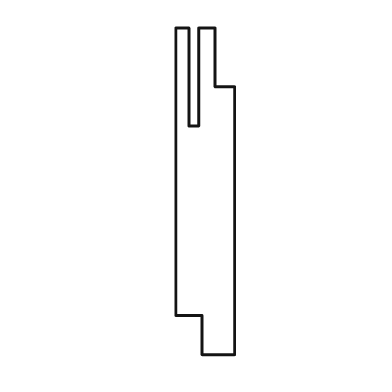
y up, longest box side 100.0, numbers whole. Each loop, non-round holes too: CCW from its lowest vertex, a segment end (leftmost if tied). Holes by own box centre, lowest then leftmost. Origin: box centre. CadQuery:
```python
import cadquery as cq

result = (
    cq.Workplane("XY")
    .moveTo(-1.0, -50.0)
    .lineTo(9.0, -50.0)
    .lineTo(9.0, 32.0)
    .lineTo(3.0, 32.0)
    .lineTo(3.0, 50.0)
    .lineTo(-2.0, 50.0)
    .lineTo(-2.0, 20.0)
    .lineTo(-5.0, 20.0)
    .lineTo(-5.0, 50.0)
    .lineTo(-9.0, 50.0)
    .lineTo(-9.0, -38.0)
    .lineTo(-1.0, -38.0)
    .close()
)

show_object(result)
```